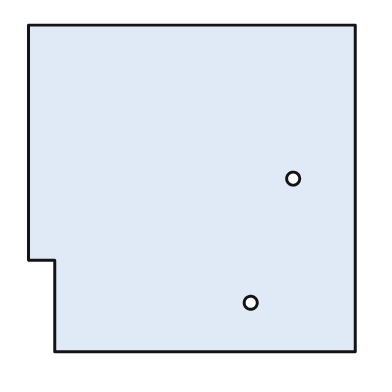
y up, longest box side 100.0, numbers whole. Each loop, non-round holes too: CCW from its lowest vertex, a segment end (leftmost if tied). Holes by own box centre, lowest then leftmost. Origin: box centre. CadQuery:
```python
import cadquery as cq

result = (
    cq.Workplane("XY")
    .moveTo(-42.0, -50.0)
    .lineTo(50.0, -50.0)
    .lineTo(50.0, 50.0)
    .lineTo(-50.0, 50.0)
    .lineTo(-50.0, -22.0)
    .lineTo(-42.0, -22.0)
    .close()
    .moveTo(18.0, -35.0)
    .circle(2.0)
    .moveTo(31.0, 3.0)
    .circle(2.0)
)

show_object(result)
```